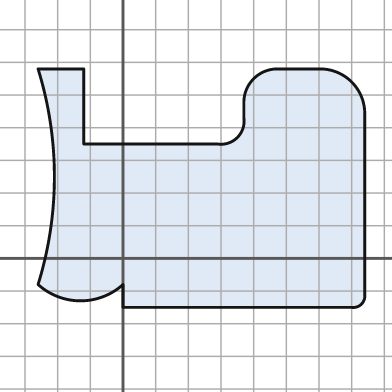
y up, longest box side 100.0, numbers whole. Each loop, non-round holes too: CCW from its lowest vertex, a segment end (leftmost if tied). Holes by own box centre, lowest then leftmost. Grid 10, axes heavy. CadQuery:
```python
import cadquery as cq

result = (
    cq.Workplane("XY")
    .moveTo(0.0, -15.0)
    .lineTo(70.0, -15.0)
    .threePointArc((73.0, -14.0), (74.0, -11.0))
    .lineTo(74.0, 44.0)
    .threePointArc((70.0, 54.0), (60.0, 58.0))
    .lineTo(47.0, 58.0)
    .threePointArc((40.0, 55.0), (37.0, 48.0))
    .lineTo(37.0, 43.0)
    .threePointArc((35.0, 37.0), (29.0, 35.0))
    .lineTo(-12.0, 35.0)
    .lineTo(-12.0, 58.0)
    .lineTo(-26.0, 58.0)
    .threePointArc((-21.0, 25.0), (-26.0, -8.0))
    .threePointArc((-13.0, -13.0), (0.0, -8.0))
    .close()
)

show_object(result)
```